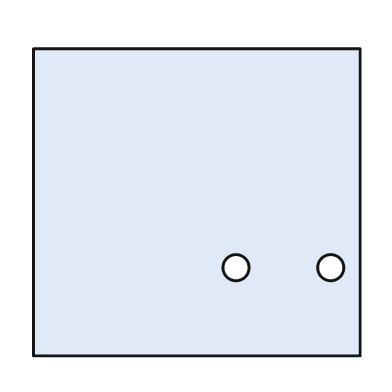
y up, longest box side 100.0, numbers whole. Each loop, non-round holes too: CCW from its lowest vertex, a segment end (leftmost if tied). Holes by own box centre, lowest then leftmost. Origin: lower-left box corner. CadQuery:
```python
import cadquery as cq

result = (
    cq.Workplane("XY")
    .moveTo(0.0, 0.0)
    .lineTo(100.0, 0.0)
    .lineTo(100.0, 94.0)
    .lineTo(0.0, 94.0)
    .close()
    .moveTo(62.0, 27.0)
    .circle(4.0)
    .moveTo(91.0, 27.0)
    .circle(4.0)
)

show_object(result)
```